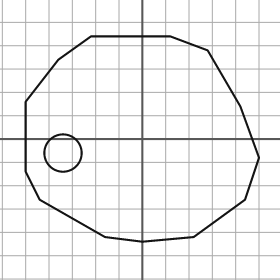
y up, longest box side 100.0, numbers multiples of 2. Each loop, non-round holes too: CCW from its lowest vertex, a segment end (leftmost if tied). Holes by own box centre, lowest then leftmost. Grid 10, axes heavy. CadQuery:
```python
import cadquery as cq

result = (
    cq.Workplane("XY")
    .moveTo(0.0, -44.0)
    .lineTo(22.0, -42.0)
    .lineTo(44.0, -26.0)
    .lineTo(50.0, -8.0)
    .lineTo(42.0, 14.0)
    .lineTo(28.0, 38.0)
    .lineTo(12.0, 44.0)
    .lineTo(-22.0, 44.0)
    .lineTo(-36.0, 34.0)
    .lineTo(-50.0, 16.0)
    .lineTo(-50.0, -14.0)
    .lineTo(-44.0, -26.0)
    .lineTo(-16.0, -42.0)
    .close()
    .moveTo(-34.0, -6.0)
    .circle(8.0)
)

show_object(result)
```